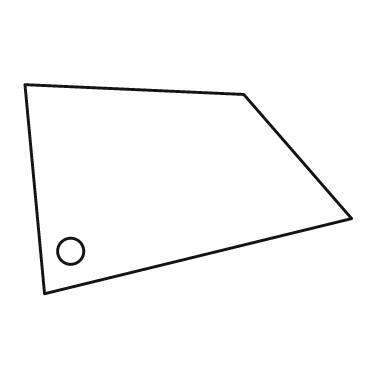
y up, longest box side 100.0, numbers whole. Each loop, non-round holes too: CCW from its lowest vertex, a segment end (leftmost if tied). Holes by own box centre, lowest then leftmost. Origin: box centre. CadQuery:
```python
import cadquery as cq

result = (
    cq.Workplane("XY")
    .moveTo(-44.0, -32.0)
    .lineTo(50.0, -9.0)
    .lineTo(17.0, 29.0)
    .lineTo(-50.0, 32.0)
    .close()
    .moveTo(-36.0, -19.0)
    .circle(4.0)
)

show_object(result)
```